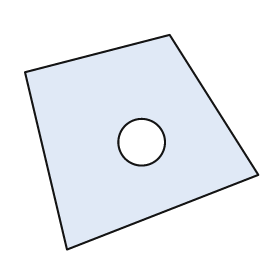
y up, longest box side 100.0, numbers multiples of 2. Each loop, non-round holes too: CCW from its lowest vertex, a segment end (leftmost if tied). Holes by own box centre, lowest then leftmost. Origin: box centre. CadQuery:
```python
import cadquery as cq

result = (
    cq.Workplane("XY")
    .moveTo(-32.0, -46.0)
    .lineTo(50.0, -14.0)
    .lineTo(12.0, 46.0)
    .lineTo(-50.0, 30.0)
    .close()
    .moveTo(0.0, 0.0)
    .circle(10.0)
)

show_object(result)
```